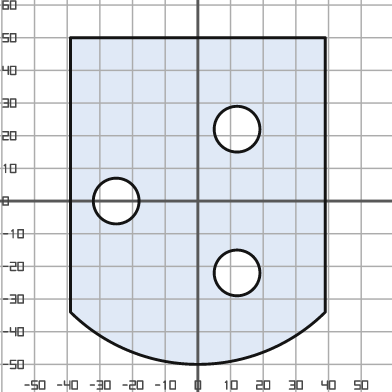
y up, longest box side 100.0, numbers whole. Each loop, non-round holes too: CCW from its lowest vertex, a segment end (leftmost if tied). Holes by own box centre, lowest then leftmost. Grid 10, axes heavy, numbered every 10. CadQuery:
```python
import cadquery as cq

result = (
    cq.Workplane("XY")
    .moveTo(-39.0, -34.0)
    .threePointArc((0.0, -50.0), (39.0, -34.0))
    .lineTo(39.0, 50.0)
    .lineTo(-39.0, 50.0)
    .close()
    .moveTo(12.0, -22.0)
    .circle(7.0)
    .moveTo(-25.0, 0.0)
    .circle(7.0)
    .moveTo(12.0, 22.0)
    .circle(7.0)
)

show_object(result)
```